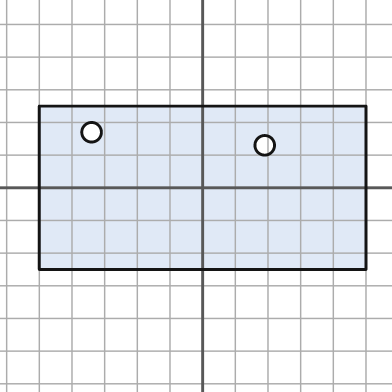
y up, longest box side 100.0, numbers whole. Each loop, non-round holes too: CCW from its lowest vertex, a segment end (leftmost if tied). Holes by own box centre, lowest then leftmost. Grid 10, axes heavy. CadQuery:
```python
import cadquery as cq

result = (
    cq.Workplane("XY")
    .moveTo(-50.0, -25.0)
    .lineTo(50.0, -25.0)
    .lineTo(50.0, 25.0)
    .lineTo(-50.0, 25.0)
    .close()
    .moveTo(19.0, 13.0)
    .circle(3.0)
    .moveTo(-34.0, 17.0)
    .circle(3.0)
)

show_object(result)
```